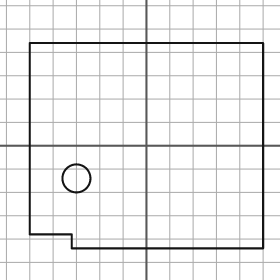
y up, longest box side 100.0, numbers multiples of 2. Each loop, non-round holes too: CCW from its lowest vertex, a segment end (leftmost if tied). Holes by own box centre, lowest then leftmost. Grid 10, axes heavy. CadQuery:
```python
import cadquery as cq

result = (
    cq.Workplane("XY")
    .moveTo(-32.0, -44.0)
    .lineTo(50.0, -44.0)
    .lineTo(50.0, 44.0)
    .lineTo(-50.0, 44.0)
    .lineTo(-50.0, -38.0)
    .lineTo(-32.0, -38.0)
    .close()
    .moveTo(-30.0, -14.0)
    .circle(6.0)
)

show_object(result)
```